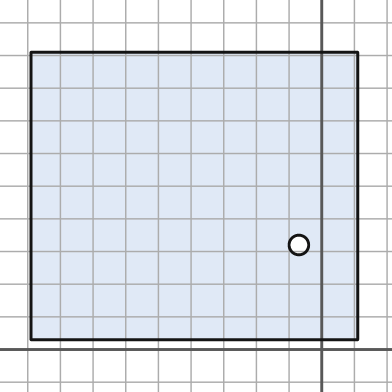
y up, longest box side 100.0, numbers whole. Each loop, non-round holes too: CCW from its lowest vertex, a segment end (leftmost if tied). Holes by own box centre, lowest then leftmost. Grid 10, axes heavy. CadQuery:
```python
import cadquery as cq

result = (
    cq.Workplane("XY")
    .moveTo(-89.0, 3.0)
    .lineTo(11.0, 3.0)
    .lineTo(11.0, 91.0)
    .lineTo(-89.0, 91.0)
    .close()
    .moveTo(-7.0, 32.0)
    .circle(3.0)
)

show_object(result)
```